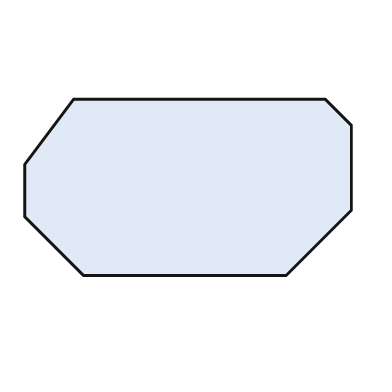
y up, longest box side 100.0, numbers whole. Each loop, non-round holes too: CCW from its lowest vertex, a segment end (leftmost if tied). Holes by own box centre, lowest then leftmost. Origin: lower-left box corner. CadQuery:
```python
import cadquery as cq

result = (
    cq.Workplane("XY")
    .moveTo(18.0, 0.0)
    .lineTo(80.0, 0.0)
    .lineTo(100.0, 20.0)
    .lineTo(100.0, 46.0)
    .lineTo(92.0, 54.0)
    .lineTo(15.0, 54.0)
    .lineTo(0.0, 34.0)
    .lineTo(0.0, 18.0)
    .close()
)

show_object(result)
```